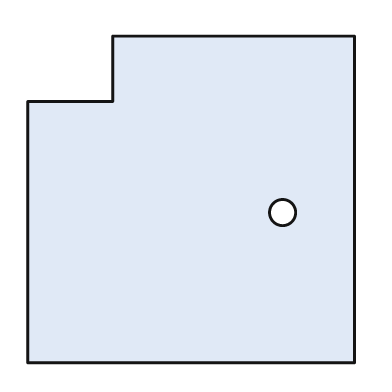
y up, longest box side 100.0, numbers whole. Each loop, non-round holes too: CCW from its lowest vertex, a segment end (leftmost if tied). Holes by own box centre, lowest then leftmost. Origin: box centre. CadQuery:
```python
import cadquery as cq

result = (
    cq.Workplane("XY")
    .moveTo(-50.0, -50.0)
    .lineTo(50.0, -50.0)
    .lineTo(50.0, 50.0)
    .lineTo(-24.0, 50.0)
    .lineTo(-24.0, 30.0)
    .lineTo(-50.0, 30.0)
    .close()
    .moveTo(28.0, -4.0)
    .circle(4.0)
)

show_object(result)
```